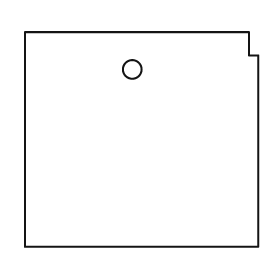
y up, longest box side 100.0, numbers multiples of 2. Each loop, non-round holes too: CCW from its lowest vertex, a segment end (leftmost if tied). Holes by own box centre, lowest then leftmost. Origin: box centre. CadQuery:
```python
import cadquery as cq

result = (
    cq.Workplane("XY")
    .moveTo(-50.0, -46.0)
    .lineTo(50.0, -46.0)
    .lineTo(50.0, 36.0)
    .lineTo(46.0, 36.0)
    .lineTo(46.0, 46.0)
    .lineTo(-50.0, 46.0)
    .close()
    .moveTo(-4.0, 30.0)
    .circle(4.0)
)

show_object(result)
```